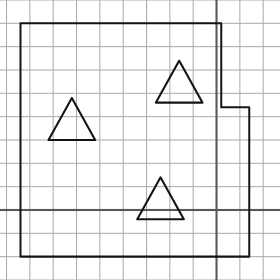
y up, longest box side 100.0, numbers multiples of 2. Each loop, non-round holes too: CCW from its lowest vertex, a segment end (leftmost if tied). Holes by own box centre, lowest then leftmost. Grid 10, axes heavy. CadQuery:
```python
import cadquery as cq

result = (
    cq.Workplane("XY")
    .moveTo(-84.0, -20.0)
    .lineTo(14.0, -20.0)
    .lineTo(14.0, 44.0)
    .lineTo(2.0, 44.0)
    .lineTo(2.0, 80.0)
    .lineTo(-84.0, 80.0)
    .close()
    .moveTo(-34.0, -4.0)
    .lineTo(-14.0, -4.0)
    .lineTo(-24.0, 14.0)
    .close()
    .moveTo(-72.0, 30.0)
    .lineTo(-52.0, 30.0)
    .lineTo(-62.0, 48.0)
    .close()
    .moveTo(-26.0, 46.0)
    .lineTo(-6.0, 46.0)
    .lineTo(-16.0, 64.0)
    .close()
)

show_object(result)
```